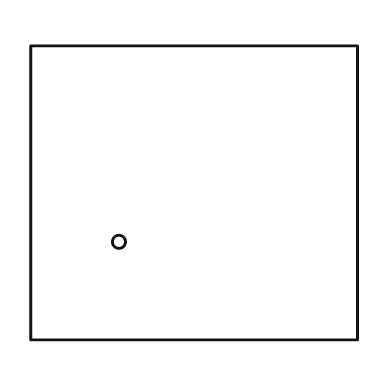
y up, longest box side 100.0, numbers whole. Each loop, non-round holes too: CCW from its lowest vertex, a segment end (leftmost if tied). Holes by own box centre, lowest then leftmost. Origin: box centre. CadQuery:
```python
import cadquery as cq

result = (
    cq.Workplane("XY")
    .moveTo(-50.0, -45.0)
    .lineTo(50.0, -45.0)
    .lineTo(50.0, 45.0)
    .lineTo(-50.0, 45.0)
    .close()
    .moveTo(-23.0, -15.0)
    .circle(2.0)
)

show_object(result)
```